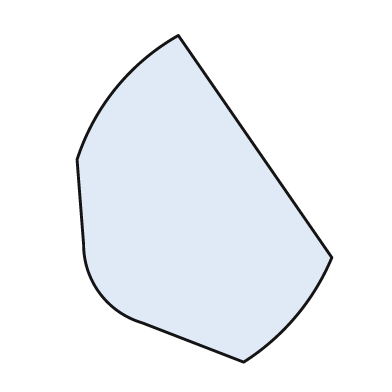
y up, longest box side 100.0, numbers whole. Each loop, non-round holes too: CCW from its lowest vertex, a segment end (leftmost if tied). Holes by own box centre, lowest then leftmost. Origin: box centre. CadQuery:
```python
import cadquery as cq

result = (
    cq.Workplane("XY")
    .moveTo(12.0, -50.0)
    .threePointArc((28.0, -36.0), (39.0, -18.0))
    .lineTo(-8.0, 50.0)
    .threePointArc((-27.0, 34.0), (-39.0, 12.0))
    .lineTo(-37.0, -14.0)
    .threePointArc((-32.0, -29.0), (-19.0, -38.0))
    .close()
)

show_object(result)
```